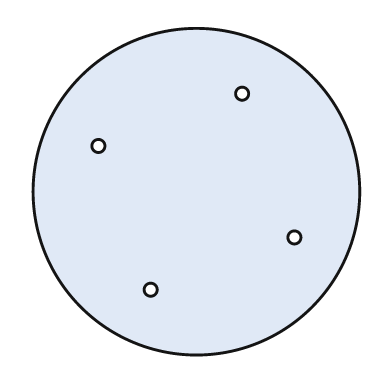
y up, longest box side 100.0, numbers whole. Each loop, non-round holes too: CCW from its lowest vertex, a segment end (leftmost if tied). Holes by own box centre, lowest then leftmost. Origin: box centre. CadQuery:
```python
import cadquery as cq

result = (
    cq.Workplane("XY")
    .moveTo(0.0, 0.0)
    .circle(50.0)
    .moveTo(-14.0, -30.0)
    .circle(2.0)
    .moveTo(30.0, -14.0)
    .circle(2.0)
    .moveTo(-30.0, 14.0)
    .circle(2.0)
    .moveTo(14.0, 30.0)
    .circle(2.0)
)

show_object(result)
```